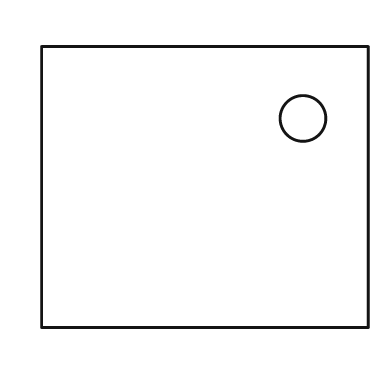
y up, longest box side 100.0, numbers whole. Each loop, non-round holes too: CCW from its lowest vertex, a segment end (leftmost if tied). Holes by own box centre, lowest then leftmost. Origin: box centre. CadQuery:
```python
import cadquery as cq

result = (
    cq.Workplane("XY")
    .moveTo(-50.0, -43.0)
    .lineTo(50.0, -43.0)
    .lineTo(50.0, 43.0)
    .lineTo(-50.0, 43.0)
    .close()
    .moveTo(30.0, 21.0)
    .circle(7.0)
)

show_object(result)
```